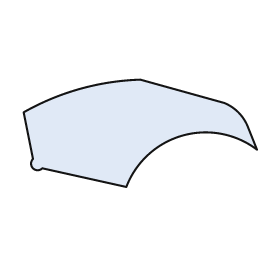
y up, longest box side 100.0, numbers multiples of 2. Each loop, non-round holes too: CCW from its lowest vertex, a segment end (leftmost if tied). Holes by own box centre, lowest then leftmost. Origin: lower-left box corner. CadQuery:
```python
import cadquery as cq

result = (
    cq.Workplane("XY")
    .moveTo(44.0, 0.0)
    .threePointArc((68.0, 22.0), (100.0, 16.0))
    .lineTo(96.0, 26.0)
    .threePointArc((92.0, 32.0), (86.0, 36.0))
    .lineTo(50.0, 46.0)
    .threePointArc((24.0, 42.0), (0.0, 32.0))
    .lineTo(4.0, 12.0)
    .threePointArc((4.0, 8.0), (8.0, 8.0))
    .close()
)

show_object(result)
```